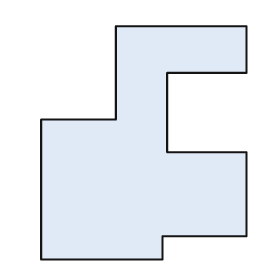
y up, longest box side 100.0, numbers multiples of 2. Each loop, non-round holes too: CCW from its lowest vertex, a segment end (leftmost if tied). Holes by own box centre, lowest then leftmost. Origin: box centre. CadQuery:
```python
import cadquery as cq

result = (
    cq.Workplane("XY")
    .moveTo(-44.0, -50.0)
    .lineTo(8.0, -50.0)
    .lineTo(8.0, -40.0)
    .lineTo(44.0, -40.0)
    .lineTo(44.0, -4.0)
    .lineTo(10.0, -4.0)
    .lineTo(10.0, 30.0)
    .lineTo(44.0, 30.0)
    .lineTo(44.0, 50.0)
    .lineTo(-12.0, 50.0)
    .lineTo(-12.0, 10.0)
    .lineTo(-44.0, 10.0)
    .close()
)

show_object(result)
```